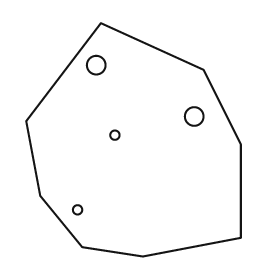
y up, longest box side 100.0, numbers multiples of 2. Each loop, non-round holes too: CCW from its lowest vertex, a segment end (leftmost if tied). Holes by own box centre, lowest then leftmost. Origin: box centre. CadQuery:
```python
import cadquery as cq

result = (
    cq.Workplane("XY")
    .moveTo(4.0, -50.0)
    .lineTo(46.0, -42.0)
    .lineTo(46.0, -2.0)
    .lineTo(30.0, 30.0)
    .lineTo(-14.0, 50.0)
    .lineTo(-46.0, 8.0)
    .lineTo(-40.0, -24.0)
    .lineTo(-22.0, -46.0)
    .close()
    .moveTo(-24.0, -30.0)
    .circle(2.0)
    .moveTo(-8.0, 2.0)
    .circle(2.0)
    .moveTo(26.0, 10.0)
    .circle(4.0)
    .moveTo(-16.0, 32.0)
    .circle(4.0)
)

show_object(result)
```